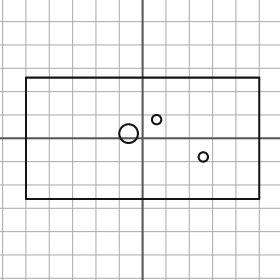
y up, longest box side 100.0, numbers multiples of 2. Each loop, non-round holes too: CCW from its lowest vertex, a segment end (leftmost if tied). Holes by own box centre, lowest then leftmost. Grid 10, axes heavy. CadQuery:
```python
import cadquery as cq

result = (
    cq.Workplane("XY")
    .moveTo(-50.0, -26.0)
    .lineTo(50.0, -26.0)
    .lineTo(50.0, 26.0)
    .lineTo(-50.0, 26.0)
    .close()
    .moveTo(26.0, -8.0)
    .circle(2.0)
    .moveTo(-6.0, 2.0)
    .circle(4.0)
    .moveTo(6.0, 8.0)
    .circle(2.0)
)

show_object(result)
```